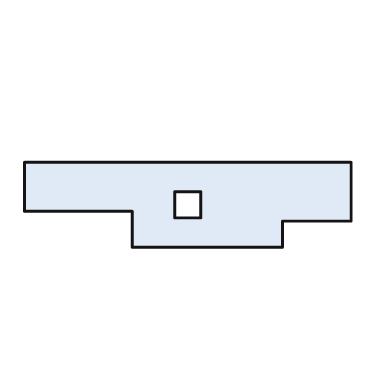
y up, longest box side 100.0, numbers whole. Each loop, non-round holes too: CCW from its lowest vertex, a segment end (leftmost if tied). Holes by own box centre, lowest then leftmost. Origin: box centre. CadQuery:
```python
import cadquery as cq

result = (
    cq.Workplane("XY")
    .moveTo(-17.0, -13.0)
    .lineTo(29.0, -13.0)
    .lineTo(29.0, -5.0)
    .lineTo(50.0, -5.0)
    .lineTo(50.0, 13.0)
    .lineTo(-50.0, 13.0)
    .lineTo(-50.0, -2.0)
    .lineTo(-17.0, -2.0)
    .close()
    .moveTo(-4.0, -4.0)
    .lineTo(4.0, -4.0)
    .lineTo(4.0, 4.0)
    .lineTo(-4.0, 4.0)
    .close()
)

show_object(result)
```